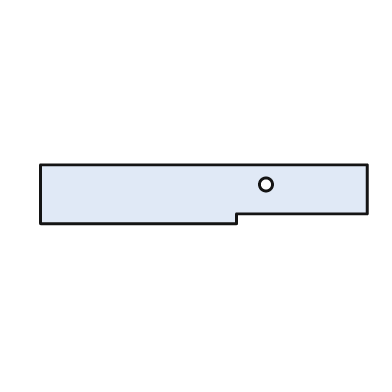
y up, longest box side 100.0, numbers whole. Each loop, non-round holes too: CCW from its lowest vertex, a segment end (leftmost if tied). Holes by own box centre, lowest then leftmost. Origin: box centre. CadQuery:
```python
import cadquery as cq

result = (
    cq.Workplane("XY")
    .moveTo(-50.0, -9.0)
    .lineTo(10.0, -9.0)
    .lineTo(10.0, -6.0)
    .lineTo(50.0, -6.0)
    .lineTo(50.0, 9.0)
    .lineTo(-50.0, 9.0)
    .close()
    .moveTo(19.0, 3.0)
    .circle(2.0)
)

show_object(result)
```